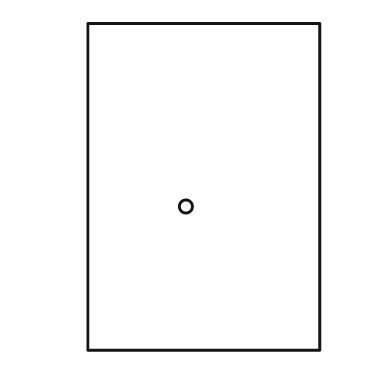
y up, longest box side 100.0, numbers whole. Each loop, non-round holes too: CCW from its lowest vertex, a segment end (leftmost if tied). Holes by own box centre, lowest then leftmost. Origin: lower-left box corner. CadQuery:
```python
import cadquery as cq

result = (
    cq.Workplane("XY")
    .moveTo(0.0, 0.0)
    .lineTo(71.0, 0.0)
    .lineTo(71.0, 100.0)
    .lineTo(0.0, 100.0)
    .close()
    .moveTo(30.0, 44.0)
    .circle(2.0)
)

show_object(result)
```